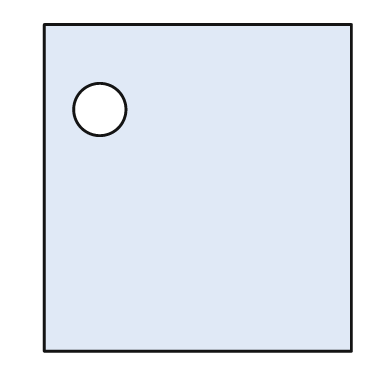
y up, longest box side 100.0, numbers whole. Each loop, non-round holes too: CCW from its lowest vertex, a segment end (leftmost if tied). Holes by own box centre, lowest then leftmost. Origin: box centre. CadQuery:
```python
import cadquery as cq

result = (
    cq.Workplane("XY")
    .moveTo(-47.0, -50.0)
    .lineTo(47.0, -50.0)
    .lineTo(47.0, 50.0)
    .lineTo(-47.0, 50.0)
    .close()
    .moveTo(-30.0, 24.0)
    .circle(8.0)
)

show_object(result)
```